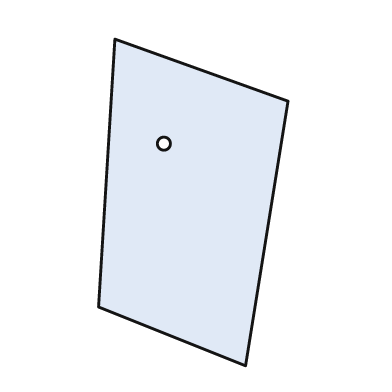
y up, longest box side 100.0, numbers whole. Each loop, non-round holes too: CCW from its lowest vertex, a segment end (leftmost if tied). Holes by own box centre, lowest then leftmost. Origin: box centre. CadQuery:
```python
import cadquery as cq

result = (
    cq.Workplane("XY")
    .moveTo(16.0, -50.0)
    .lineTo(29.0, 31.0)
    .lineTo(-24.0, 50.0)
    .lineTo(-29.0, -32.0)
    .close()
    .moveTo(-9.0, 18.0)
    .circle(2.0)
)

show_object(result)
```